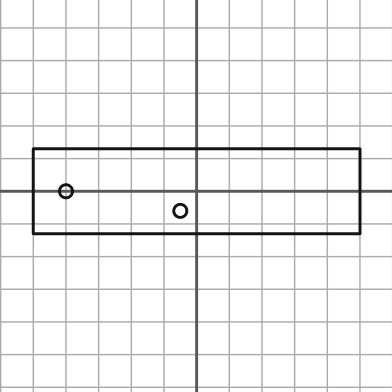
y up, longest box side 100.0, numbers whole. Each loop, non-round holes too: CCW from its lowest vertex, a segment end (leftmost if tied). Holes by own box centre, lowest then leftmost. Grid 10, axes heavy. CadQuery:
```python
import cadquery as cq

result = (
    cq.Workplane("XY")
    .moveTo(-50.0, -13.0)
    .lineTo(50.0, -13.0)
    .lineTo(50.0, 13.0)
    .lineTo(-50.0, 13.0)
    .close()
    .moveTo(-5.0, -6.0)
    .circle(2.0)
    .moveTo(-40.0, 0.0)
    .circle(2.0)
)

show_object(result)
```